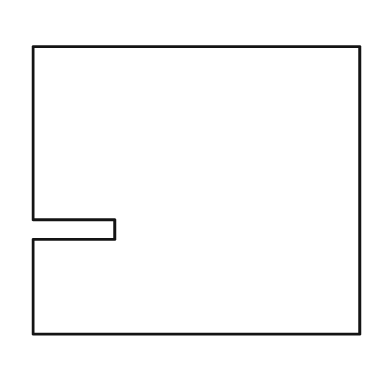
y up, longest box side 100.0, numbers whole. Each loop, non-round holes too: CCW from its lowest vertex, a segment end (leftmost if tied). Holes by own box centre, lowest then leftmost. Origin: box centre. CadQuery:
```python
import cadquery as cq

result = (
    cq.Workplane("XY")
    .moveTo(-50.0, -44.0)
    .lineTo(50.0, -44.0)
    .lineTo(50.0, 44.0)
    .lineTo(-50.0, 44.0)
    .lineTo(-50.0, -9.0)
    .lineTo(-25.0, -9.0)
    .lineTo(-25.0, -15.0)
    .lineTo(-50.0, -15.0)
    .close()
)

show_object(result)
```